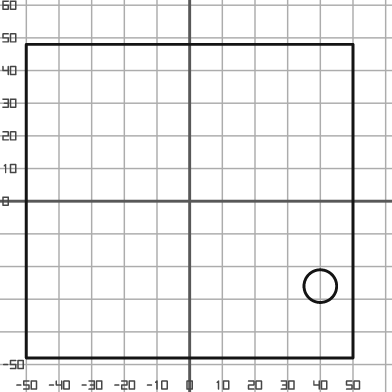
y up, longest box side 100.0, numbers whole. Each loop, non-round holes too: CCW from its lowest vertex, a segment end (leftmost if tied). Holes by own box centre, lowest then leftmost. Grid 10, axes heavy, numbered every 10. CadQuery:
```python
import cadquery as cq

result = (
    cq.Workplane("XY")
    .moveTo(-50.0, -48.0)
    .lineTo(50.0, -48.0)
    .lineTo(50.0, 48.0)
    .lineTo(-50.0, 48.0)
    .close()
    .moveTo(40.0, -26.0)
    .circle(5.0)
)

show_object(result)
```